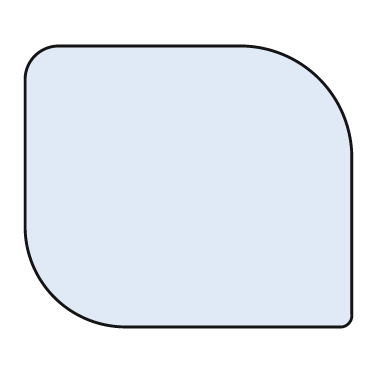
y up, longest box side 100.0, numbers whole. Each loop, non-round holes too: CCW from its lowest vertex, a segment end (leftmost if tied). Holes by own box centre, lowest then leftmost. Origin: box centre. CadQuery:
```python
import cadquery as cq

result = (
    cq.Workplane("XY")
    .moveTo(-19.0, -43.0)
    .lineTo(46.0, -43.0)
    .threePointArc((49.0, -42.0), (50.0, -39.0))
    .lineTo(50.0, 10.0)
    .threePointArc((40.0, 33.0), (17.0, 43.0))
    .lineTo(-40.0, 43.0)
    .threePointArc((-47.0, 40.0), (-50.0, 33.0))
    .lineTo(-50.0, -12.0)
    .threePointArc((-41.0, -34.0), (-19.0, -43.0))
    .close()
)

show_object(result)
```